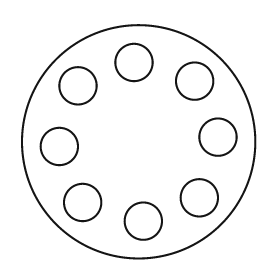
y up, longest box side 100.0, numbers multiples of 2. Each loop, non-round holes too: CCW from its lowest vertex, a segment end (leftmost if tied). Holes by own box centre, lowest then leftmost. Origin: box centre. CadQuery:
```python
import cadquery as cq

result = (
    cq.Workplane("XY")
    .moveTo(0.0, 0.0)
    .circle(50.0)
    .moveTo(2.0, -34.0)
    .circle(8.0)
    .moveTo(-24.0, -26.0)
    .circle(8.0)
    .moveTo(26.0, -24.0)
    .circle(8.0)
    .moveTo(-34.0, -2.0)
    .circle(8.0)
    .moveTo(34.0, 2.0)
    .circle(8.0)
    .moveTo(-26.0, 24.0)
    .circle(8.0)
    .moveTo(24.0, 26.0)
    .circle(8.0)
    .moveTo(-2.0, 34.0)
    .circle(8.0)
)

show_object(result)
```